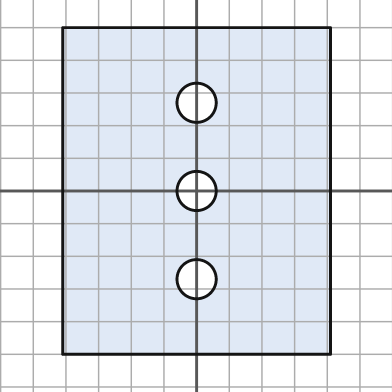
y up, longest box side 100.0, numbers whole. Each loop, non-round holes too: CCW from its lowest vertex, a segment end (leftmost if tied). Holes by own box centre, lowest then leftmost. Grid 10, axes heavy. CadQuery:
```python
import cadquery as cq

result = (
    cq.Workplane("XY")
    .moveTo(-41.0, -50.0)
    .lineTo(41.0, -50.0)
    .lineTo(41.0, 50.0)
    .lineTo(-41.0, 50.0)
    .close()
    .moveTo(0.0, -27.0)
    .circle(6.0)
    .moveTo(0.0, 0.0)
    .circle(6.0)
    .moveTo(0.0, 27.0)
    .circle(6.0)
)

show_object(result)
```